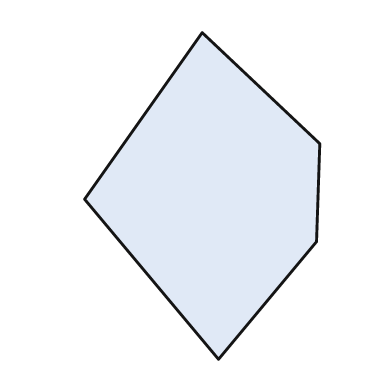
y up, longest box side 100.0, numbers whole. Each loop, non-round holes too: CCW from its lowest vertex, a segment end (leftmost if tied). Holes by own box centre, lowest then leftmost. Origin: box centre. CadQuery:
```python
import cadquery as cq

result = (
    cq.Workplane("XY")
    .moveTo(5.0, -50.0)
    .lineTo(35.0, -14.0)
    .lineTo(36.0, 16.0)
    .lineTo(0.0, 50.0)
    .lineTo(-36.0, -1.0)
    .close()
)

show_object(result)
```